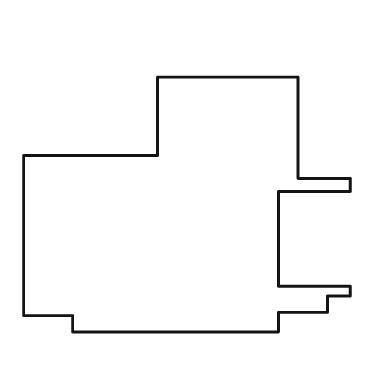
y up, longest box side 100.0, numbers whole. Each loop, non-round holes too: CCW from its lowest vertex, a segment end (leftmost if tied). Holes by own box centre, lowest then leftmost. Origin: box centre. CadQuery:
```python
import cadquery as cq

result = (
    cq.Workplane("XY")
    .moveTo(-35.0, -39.0)
    .lineTo(28.0, -39.0)
    .lineTo(28.0, -33.0)
    .lineTo(43.0, -33.0)
    .lineTo(43.0, -28.0)
    .lineTo(50.0, -28.0)
    .lineTo(50.0, -25.0)
    .lineTo(28.0, -25.0)
    .lineTo(28.0, 4.0)
    .lineTo(50.0, 4.0)
    .lineTo(50.0, 8.0)
    .lineTo(34.0, 8.0)
    .lineTo(34.0, 39.0)
    .lineTo(-9.0, 39.0)
    .lineTo(-9.0, 15.0)
    .lineTo(-50.0, 15.0)
    .lineTo(-50.0, -34.0)
    .lineTo(-35.0, -34.0)
    .close()
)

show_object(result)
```